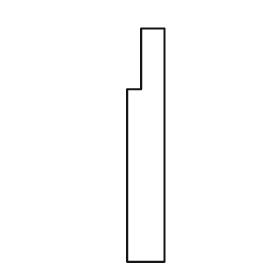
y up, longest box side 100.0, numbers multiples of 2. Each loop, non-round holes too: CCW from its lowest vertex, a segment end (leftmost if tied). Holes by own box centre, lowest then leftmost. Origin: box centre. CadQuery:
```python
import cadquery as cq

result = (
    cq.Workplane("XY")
    .moveTo(-8.0, -50.0)
    .lineTo(8.0, -50.0)
    .lineTo(8.0, 50.0)
    .lineTo(-2.0, 50.0)
    .lineTo(-2.0, 24.0)
    .lineTo(-8.0, 24.0)
    .close()
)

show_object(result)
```